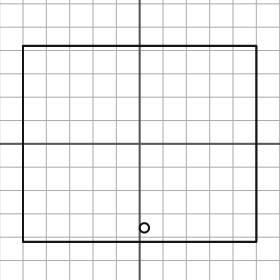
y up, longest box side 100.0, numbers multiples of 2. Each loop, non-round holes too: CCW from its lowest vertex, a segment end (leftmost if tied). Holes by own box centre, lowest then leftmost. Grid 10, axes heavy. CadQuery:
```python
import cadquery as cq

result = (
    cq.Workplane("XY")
    .moveTo(-50.0, -42.0)
    .lineTo(50.0, -42.0)
    .lineTo(50.0, 42.0)
    .lineTo(-50.0, 42.0)
    .close()
    .moveTo(2.0, -36.0)
    .circle(2.0)
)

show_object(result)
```